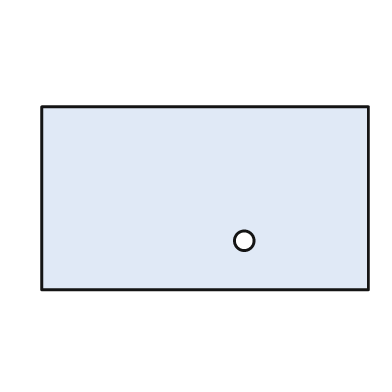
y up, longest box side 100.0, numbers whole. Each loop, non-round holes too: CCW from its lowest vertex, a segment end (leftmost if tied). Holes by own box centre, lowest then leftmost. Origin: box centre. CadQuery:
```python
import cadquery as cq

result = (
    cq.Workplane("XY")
    .moveTo(-50.0, -28.0)
    .lineTo(50.0, -28.0)
    .lineTo(50.0, 28.0)
    .lineTo(-50.0, 28.0)
    .close()
    .moveTo(12.0, -13.0)
    .circle(3.0)
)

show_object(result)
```